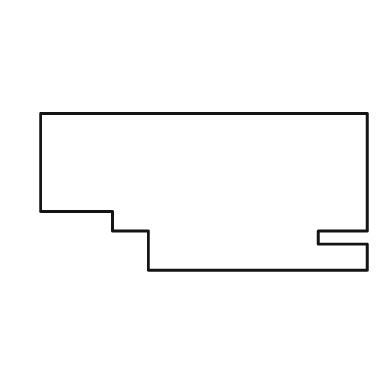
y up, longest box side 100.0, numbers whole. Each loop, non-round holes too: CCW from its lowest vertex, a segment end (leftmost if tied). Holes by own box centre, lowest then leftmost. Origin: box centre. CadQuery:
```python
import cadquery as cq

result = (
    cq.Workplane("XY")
    .moveTo(-17.0, -24.0)
    .lineTo(50.0, -24.0)
    .lineTo(50.0, -16.0)
    .lineTo(35.0, -16.0)
    .lineTo(35.0, -12.0)
    .lineTo(50.0, -12.0)
    .lineTo(50.0, 24.0)
    .lineTo(-50.0, 24.0)
    .lineTo(-50.0, -6.0)
    .lineTo(-28.0, -6.0)
    .lineTo(-28.0, -12.0)
    .lineTo(-17.0, -12.0)
    .close()
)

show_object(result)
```